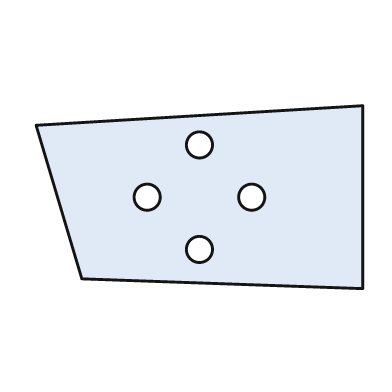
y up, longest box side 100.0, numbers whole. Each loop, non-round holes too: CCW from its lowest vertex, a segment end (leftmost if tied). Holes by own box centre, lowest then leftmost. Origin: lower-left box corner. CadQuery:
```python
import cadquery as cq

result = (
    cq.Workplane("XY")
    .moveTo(100.0, 0.0)
    .lineTo(100.0, 56.0)
    .lineTo(0.0, 50.0)
    .lineTo(14.0, 3.0)
    .close()
    .moveTo(50.0, 12.0)
    .circle(4.0)
    .moveTo(34.0, 28.0)
    .circle(4.0)
    .moveTo(66.0, 28.0)
    .circle(4.0)
    .moveTo(50.0, 44.0)
    .circle(4.0)
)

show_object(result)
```